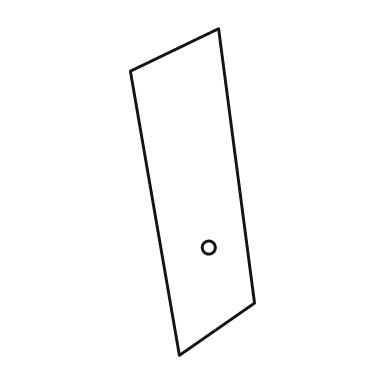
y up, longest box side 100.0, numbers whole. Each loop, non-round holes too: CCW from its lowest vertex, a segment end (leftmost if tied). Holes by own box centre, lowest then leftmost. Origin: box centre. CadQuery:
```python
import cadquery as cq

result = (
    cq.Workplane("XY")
    .moveTo(-4.0, -50.0)
    .lineTo(19.0, -34.0)
    .lineTo(8.0, 50.0)
    .lineTo(-19.0, 37.0)
    .close()
    .moveTo(5.0, -17.0)
    .circle(2.0)
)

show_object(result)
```